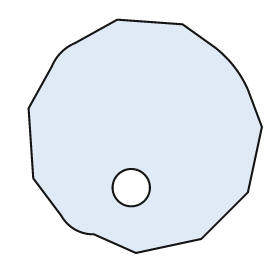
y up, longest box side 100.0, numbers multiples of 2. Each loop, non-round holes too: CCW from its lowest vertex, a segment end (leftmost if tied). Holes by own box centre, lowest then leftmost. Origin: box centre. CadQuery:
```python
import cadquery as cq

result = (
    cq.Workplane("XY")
    .moveTo(-4.0, -50.0)
    .lineTo(24.0, -44.0)
    .lineTo(44.0, -24.0)
    .lineTo(50.0, 4.0)
    .lineTo(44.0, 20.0)
    .threePointArc((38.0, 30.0), (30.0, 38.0))
    .lineTo(16.0, 48.0)
    .lineTo(-12.0, 50.0)
    .lineTo(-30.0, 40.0)
    .threePointArc((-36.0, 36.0), (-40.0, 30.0))
    .lineTo(-50.0, 12.0)
    .lineTo(-48.0, -18.0)
    .lineTo(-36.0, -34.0)
    .threePointArc((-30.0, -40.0), (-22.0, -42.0))
    .close()
    .moveTo(-6.0, -22.0)
    .circle(8.0)
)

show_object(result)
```